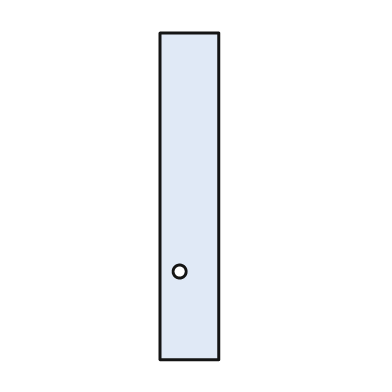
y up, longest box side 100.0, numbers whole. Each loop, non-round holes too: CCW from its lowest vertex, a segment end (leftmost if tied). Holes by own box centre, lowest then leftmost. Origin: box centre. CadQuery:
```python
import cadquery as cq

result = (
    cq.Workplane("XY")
    .moveTo(-9.0, -50.0)
    .lineTo(9.0, -50.0)
    .lineTo(9.0, 50.0)
    .lineTo(-9.0, 50.0)
    .close()
    .moveTo(-3.0, -23.0)
    .circle(2.0)
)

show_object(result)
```